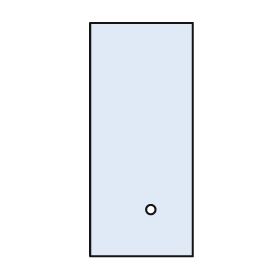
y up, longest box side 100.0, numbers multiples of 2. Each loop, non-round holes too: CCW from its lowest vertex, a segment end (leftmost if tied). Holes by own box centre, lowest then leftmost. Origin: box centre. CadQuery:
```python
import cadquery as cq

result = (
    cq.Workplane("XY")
    .moveTo(-22.0, -50.0)
    .lineTo(22.0, -50.0)
    .lineTo(22.0, 50.0)
    .lineTo(-22.0, 50.0)
    .close()
    .moveTo(4.0, -30.0)
    .circle(2.0)
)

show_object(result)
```